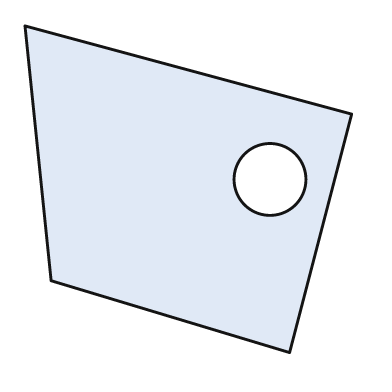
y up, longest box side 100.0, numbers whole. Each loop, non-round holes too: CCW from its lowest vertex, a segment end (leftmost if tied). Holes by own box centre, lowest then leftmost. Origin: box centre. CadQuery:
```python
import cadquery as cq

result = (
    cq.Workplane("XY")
    .moveTo(31.0, -50.0)
    .lineTo(50.0, 23.0)
    .lineTo(-50.0, 50.0)
    .lineTo(-42.0, -28.0)
    .close()
    .moveTo(25.0, 3.0)
    .circle(11.0)
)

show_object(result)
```